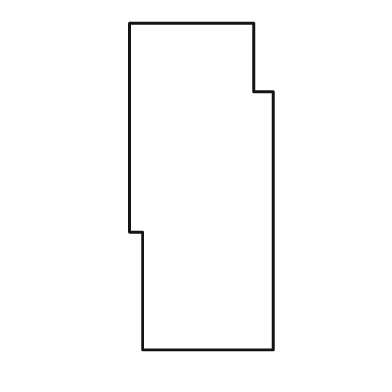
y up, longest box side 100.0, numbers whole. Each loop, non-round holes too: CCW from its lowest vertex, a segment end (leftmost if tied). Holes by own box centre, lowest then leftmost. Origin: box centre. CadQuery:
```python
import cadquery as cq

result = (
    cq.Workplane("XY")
    .moveTo(-18.0, -50.0)
    .lineTo(22.0, -50.0)
    .lineTo(22.0, 29.0)
    .lineTo(16.0, 29.0)
    .lineTo(16.0, 50.0)
    .lineTo(-22.0, 50.0)
    .lineTo(-22.0, -14.0)
    .lineTo(-18.0, -14.0)
    .close()
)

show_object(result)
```